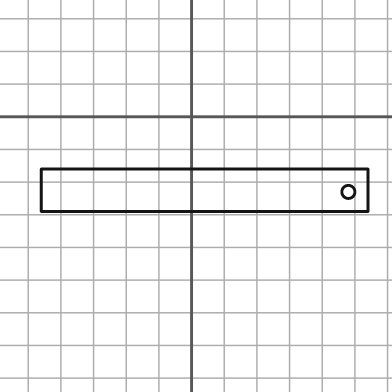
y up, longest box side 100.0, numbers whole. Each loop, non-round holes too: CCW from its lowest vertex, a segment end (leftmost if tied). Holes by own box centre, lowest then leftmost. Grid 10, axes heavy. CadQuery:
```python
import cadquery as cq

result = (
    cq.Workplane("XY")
    .moveTo(-46.0, -29.0)
    .lineTo(54.0, -29.0)
    .lineTo(54.0, -16.0)
    .lineTo(-46.0, -16.0)
    .close()
    .moveTo(48.0, -23.0)
    .circle(2.0)
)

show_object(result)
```